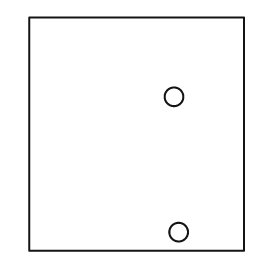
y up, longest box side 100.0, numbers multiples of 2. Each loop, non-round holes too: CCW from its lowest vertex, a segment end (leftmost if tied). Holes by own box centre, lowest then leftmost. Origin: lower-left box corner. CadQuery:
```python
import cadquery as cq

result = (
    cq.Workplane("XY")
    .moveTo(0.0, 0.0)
    .lineTo(92.0, 0.0)
    .lineTo(92.0, 100.0)
    .lineTo(0.0, 100.0)
    .close()
    .moveTo(64.0, 8.0)
    .circle(4.0)
    .moveTo(62.0, 66.0)
    .circle(4.0)
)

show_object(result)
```